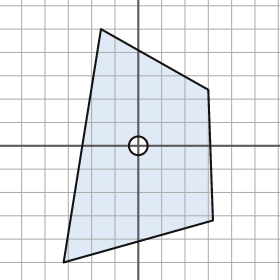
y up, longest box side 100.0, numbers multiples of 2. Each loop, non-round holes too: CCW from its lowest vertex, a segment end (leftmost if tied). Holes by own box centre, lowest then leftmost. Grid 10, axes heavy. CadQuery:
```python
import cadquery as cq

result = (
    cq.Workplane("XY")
    .moveTo(-32.0, -50.0)
    .lineTo(32.0, -32.0)
    .lineTo(30.0, 24.0)
    .lineTo(-16.0, 50.0)
    .close()
    .moveTo(0.0, 0.0)
    .circle(4.0)
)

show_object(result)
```